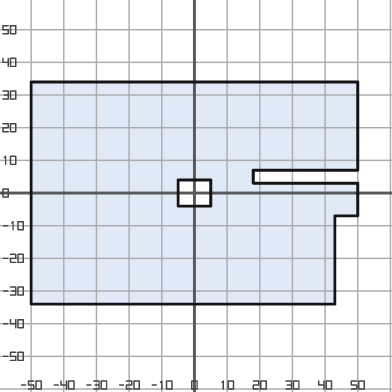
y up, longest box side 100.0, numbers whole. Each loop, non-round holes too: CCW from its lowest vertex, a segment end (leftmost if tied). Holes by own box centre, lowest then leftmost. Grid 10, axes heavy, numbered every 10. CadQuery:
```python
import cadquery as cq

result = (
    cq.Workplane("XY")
    .moveTo(-50.0, -34.0)
    .lineTo(43.0, -34.0)
    .lineTo(43.0, -7.0)
    .lineTo(50.0, -7.0)
    .lineTo(50.0, 3.0)
    .lineTo(18.0, 3.0)
    .lineTo(18.0, 7.0)
    .lineTo(50.0, 7.0)
    .lineTo(50.0, 34.0)
    .lineTo(-50.0, 34.0)
    .close()
    .moveTo(-5.0, -4.0)
    .lineTo(5.0, -4.0)
    .lineTo(5.0, 4.0)
    .lineTo(-5.0, 4.0)
    .close()
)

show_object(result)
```